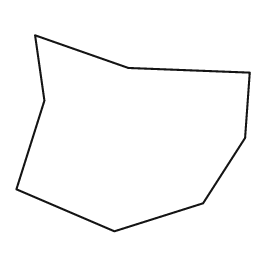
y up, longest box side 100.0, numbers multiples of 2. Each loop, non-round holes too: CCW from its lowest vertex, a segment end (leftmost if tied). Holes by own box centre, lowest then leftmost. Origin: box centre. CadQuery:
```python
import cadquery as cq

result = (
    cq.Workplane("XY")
    .moveTo(-8.0, -42.0)
    .lineTo(30.0, -30.0)
    .lineTo(48.0, -2.0)
    .lineTo(50.0, 26.0)
    .lineTo(-2.0, 28.0)
    .lineTo(-42.0, 42.0)
    .lineTo(-38.0, 14.0)
    .lineTo(-50.0, -24.0)
    .close()
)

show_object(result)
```